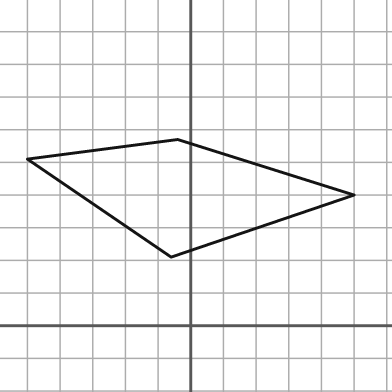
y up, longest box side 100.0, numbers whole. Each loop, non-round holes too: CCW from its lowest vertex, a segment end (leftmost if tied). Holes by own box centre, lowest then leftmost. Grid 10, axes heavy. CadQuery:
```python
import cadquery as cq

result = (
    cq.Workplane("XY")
    .moveTo(-6.0, 21.0)
    .lineTo(50.0, 40.0)
    .lineTo(-4.0, 57.0)
    .lineTo(-50.0, 51.0)
    .close()
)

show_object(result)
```